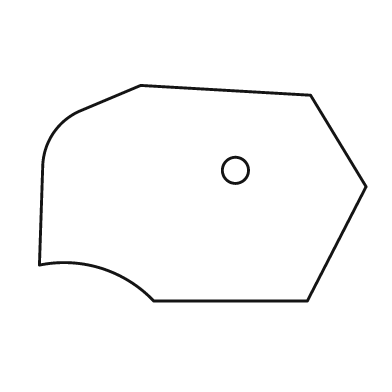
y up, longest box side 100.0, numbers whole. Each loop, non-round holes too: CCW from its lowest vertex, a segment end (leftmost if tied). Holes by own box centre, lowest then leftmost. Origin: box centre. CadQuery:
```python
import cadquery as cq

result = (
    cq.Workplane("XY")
    .moveTo(-15.0, -33.0)
    .lineTo(32.0, -33.0)
    .lineTo(50.0, 2.0)
    .lineTo(33.0, 30.0)
    .lineTo(-19.0, 33.0)
    .lineTo(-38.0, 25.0)
    .threePointArc((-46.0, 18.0), (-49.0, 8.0))
    .lineTo(-50.0, -22.0)
    .threePointArc((-31.0, -23.0), (-15.0, -33.0))
    .close()
    .moveTo(10.0, 7.0)
    .circle(4.0)
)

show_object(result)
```